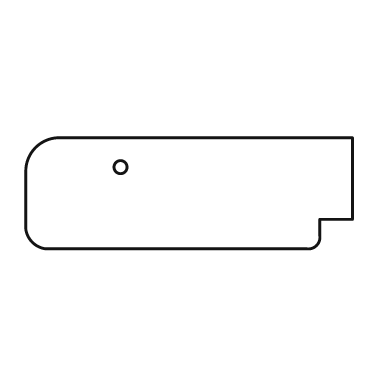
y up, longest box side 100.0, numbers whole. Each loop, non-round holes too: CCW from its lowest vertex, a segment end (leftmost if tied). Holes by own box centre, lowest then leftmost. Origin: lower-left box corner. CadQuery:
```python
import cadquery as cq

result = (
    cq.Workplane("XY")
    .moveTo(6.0, 0.0)
    .lineTo(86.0, 0.0)
    .threePointArc((89.0, 1.0), (90.0, 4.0))
    .lineTo(90.0, 9.0)
    .lineTo(100.0, 9.0)
    .lineTo(100.0, 34.0)
    .lineTo(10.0, 34.0)
    .threePointArc((3.0, 31.0), (0.0, 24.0))
    .lineTo(0.0, 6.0)
    .threePointArc((2.0, 2.0), (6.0, 0.0))
    .close()
    .moveTo(29.0, 25.0)
    .circle(2.0)
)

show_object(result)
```